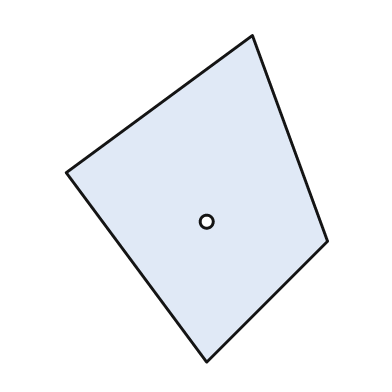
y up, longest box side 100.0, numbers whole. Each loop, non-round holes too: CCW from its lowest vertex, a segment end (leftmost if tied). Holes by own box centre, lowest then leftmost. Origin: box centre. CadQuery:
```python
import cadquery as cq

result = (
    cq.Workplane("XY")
    .moveTo(3.0, -50.0)
    .lineTo(40.0, -13.0)
    .lineTo(17.0, 50.0)
    .lineTo(-40.0, 8.0)
    .close()
    .moveTo(3.0, -7.0)
    .circle(2.0)
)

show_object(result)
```